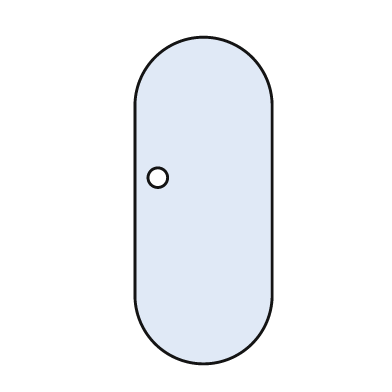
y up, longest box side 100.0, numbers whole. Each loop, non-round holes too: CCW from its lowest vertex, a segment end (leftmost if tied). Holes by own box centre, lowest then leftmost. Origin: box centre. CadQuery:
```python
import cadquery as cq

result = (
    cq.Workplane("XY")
    .moveTo(-21.0, -29.0)
    .threePointArc((0.0, -50.0), (21.0, -29.0))
    .lineTo(21.0, 29.0)
    .threePointArc((0.0, 50.0), (-21.0, 29.0))
    .close()
    .moveTo(-14.0, 7.0)
    .circle(3.0)
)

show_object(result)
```